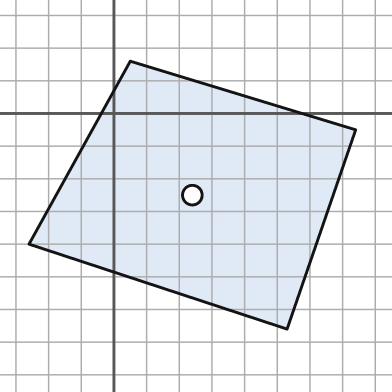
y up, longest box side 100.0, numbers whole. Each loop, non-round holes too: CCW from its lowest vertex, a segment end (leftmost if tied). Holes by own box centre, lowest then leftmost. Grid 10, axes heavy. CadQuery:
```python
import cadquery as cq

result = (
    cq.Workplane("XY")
    .moveTo(53.0, -66.0)
    .lineTo(74.0, -5.0)
    .lineTo(5.0, 16.0)
    .lineTo(-26.0, -40.0)
    .close()
    .moveTo(24.0, -25.0)
    .circle(3.0)
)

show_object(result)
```